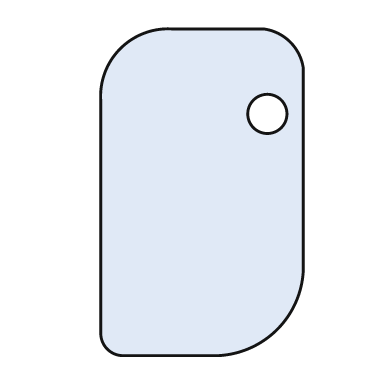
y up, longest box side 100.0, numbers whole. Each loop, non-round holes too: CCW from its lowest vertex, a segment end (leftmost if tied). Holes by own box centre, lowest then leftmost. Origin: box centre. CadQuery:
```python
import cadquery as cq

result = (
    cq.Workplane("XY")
    .moveTo(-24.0, -50.0)
    .lineTo(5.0, -50.0)
    .threePointArc((23.0, -42.0), (31.0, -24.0))
    .lineTo(31.0, 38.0)
    .threePointArc((27.0, 46.0), (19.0, 50.0))
    .lineTo(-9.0, 50.0)
    .threePointArc((-25.0, 44.0), (-31.0, 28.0))
    .lineTo(-31.0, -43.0)
    .threePointArc((-29.0, -48.0), (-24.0, -50.0))
    .close()
    .moveTo(20.0, 24.0)
    .circle(6.0)
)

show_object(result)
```